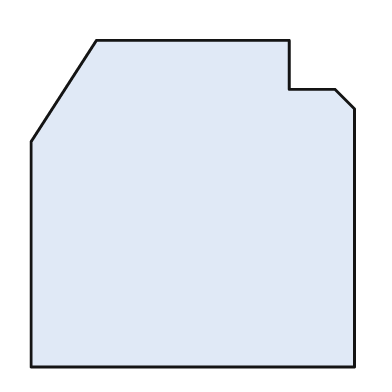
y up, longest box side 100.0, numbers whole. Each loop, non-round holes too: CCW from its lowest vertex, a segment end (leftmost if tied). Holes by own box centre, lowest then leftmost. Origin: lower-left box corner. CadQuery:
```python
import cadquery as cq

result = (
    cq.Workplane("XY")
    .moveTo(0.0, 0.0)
    .lineTo(99.0, 0.0)
    .lineTo(99.0, 79.0)
    .lineTo(93.0, 85.0)
    .lineTo(79.0, 85.0)
    .lineTo(79.0, 100.0)
    .lineTo(20.0, 100.0)
    .lineTo(0.0, 69.0)
    .close()
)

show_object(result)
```